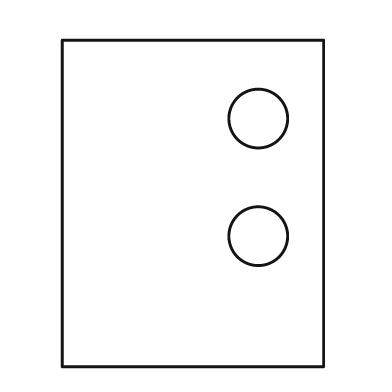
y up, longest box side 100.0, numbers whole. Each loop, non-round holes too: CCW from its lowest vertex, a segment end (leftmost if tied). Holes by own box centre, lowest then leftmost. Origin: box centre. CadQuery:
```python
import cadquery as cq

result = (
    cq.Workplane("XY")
    .moveTo(-40.0, -50.0)
    .lineTo(40.0, -50.0)
    .lineTo(40.0, 50.0)
    .lineTo(-40.0, 50.0)
    .close()
    .moveTo(20.0, -10.0)
    .circle(9.0)
    .moveTo(20.0, 26.0)
    .circle(9.0)
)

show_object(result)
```